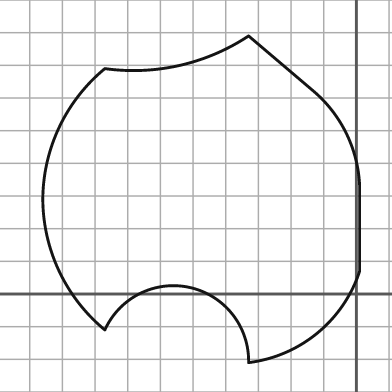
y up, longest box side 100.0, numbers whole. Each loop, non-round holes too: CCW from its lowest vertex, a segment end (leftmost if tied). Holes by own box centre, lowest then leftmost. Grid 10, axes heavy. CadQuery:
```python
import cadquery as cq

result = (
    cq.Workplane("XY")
    .moveTo(-33.0, -21.0)
    .threePointArc((-12.0, -12.0), (1.0, 7.0))
    .lineTo(1.0, 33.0)
    .threePointArc((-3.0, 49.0), (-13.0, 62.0))
    .lineTo(-33.0, 79.0)
    .threePointArc((-54.0, 70.0), (-77.0, 69.0))
    .threePointArc((-91.0, 51.0), (-96.0, 29.0))
    .threePointArc((-91.0, 7.0), (-77.0, -11.0))
    .threePointArc((-51.0, 2.0), (-33.0, -21.0))
    .close()
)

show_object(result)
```